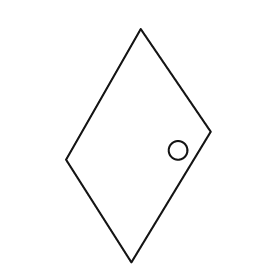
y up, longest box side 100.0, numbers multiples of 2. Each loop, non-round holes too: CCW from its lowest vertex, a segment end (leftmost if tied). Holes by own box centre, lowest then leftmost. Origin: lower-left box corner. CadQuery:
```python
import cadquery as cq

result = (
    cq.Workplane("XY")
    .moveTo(28.0, 0.0)
    .lineTo(62.0, 56.0)
    .lineTo(32.0, 100.0)
    .lineTo(0.0, 44.0)
    .close()
    .moveTo(48.0, 48.0)
    .circle(4.0)
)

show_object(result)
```